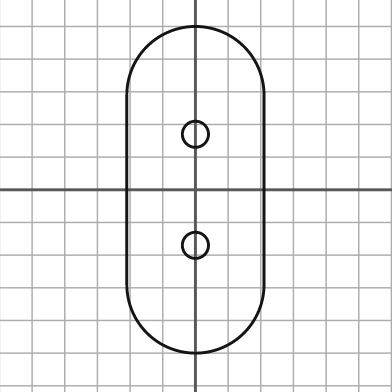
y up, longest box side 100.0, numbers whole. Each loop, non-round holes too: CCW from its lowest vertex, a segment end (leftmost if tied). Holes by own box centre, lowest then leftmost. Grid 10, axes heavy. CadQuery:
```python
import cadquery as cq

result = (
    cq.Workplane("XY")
    .moveTo(-21.0, -29.0)
    .threePointArc((0.0, -50.0), (21.0, -29.0))
    .lineTo(21.0, 29.0)
    .threePointArc((0.0, 50.0), (-21.0, 29.0))
    .close()
    .moveTo(0.0, -17.0)
    .circle(4.0)
    .moveTo(0.0, 17.0)
    .circle(4.0)
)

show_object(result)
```